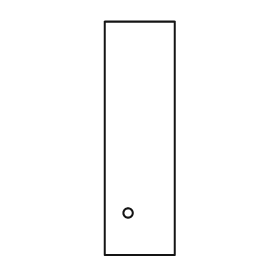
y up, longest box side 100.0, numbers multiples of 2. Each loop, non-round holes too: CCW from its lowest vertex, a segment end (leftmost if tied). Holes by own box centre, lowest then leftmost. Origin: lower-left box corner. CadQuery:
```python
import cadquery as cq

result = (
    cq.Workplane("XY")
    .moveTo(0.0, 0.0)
    .lineTo(30.0, 0.0)
    .lineTo(30.0, 100.0)
    .lineTo(0.0, 100.0)
    .close()
    .moveTo(10.0, 18.0)
    .circle(2.0)
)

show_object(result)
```